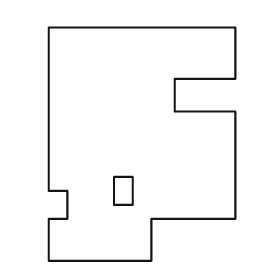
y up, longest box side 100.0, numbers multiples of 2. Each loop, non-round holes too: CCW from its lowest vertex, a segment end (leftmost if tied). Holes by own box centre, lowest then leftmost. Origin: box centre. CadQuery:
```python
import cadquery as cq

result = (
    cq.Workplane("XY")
    .moveTo(-40.0, -50.0)
    .lineTo(4.0, -50.0)
    .lineTo(4.0, -32.0)
    .lineTo(40.0, -32.0)
    .lineTo(40.0, 14.0)
    .lineTo(14.0, 14.0)
    .lineTo(14.0, 28.0)
    .lineTo(40.0, 28.0)
    .lineTo(40.0, 50.0)
    .lineTo(-40.0, 50.0)
    .lineTo(-40.0, -20.0)
    .lineTo(-32.0, -20.0)
    .lineTo(-32.0, -32.0)
    .lineTo(-40.0, -32.0)
    .close()
    .moveTo(-12.0, -26.0)
    .lineTo(-4.0, -26.0)
    .lineTo(-4.0, -14.0)
    .lineTo(-12.0, -14.0)
    .close()
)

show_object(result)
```